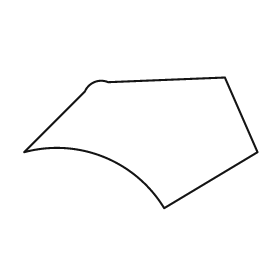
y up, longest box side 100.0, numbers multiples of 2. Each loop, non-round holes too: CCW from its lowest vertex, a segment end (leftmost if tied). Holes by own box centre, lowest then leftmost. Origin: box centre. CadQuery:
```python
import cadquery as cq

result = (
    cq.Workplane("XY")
    .moveTo(10.0, -28.0)
    .lineTo(50.0, -4.0)
    .lineTo(36.0, 28.0)
    .lineTo(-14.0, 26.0)
    .threePointArc((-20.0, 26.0), (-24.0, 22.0))
    .lineTo(-50.0, -4.0)
    .threePointArc((-16.0, -6.0), (10.0, -28.0))
    .close()
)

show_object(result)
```